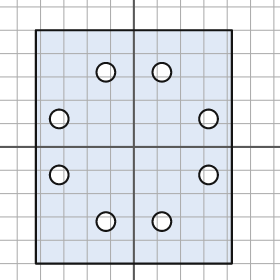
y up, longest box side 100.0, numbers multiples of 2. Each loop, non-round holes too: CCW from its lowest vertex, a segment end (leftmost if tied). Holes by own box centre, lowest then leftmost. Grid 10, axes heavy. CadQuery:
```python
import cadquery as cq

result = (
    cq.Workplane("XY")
    .moveTo(-42.0, -50.0)
    .lineTo(42.0, -50.0)
    .lineTo(42.0, 50.0)
    .lineTo(-42.0, 50.0)
    .close()
    .moveTo(-12.0, -32.0)
    .circle(4.0)
    .moveTo(12.0, -32.0)
    .circle(4.0)
    .moveTo(-32.0, -12.0)
    .circle(4.0)
    .moveTo(32.0, -12.0)
    .circle(4.0)
    .moveTo(-32.0, 12.0)
    .circle(4.0)
    .moveTo(32.0, 12.0)
    .circle(4.0)
    .moveTo(-12.0, 32.0)
    .circle(4.0)
    .moveTo(12.0, 32.0)
    .circle(4.0)
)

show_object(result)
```